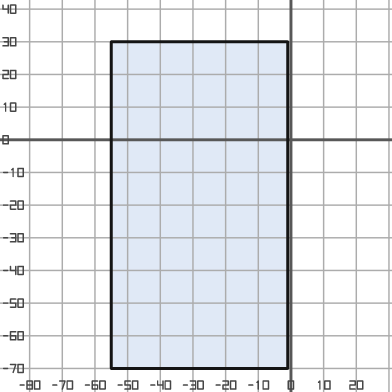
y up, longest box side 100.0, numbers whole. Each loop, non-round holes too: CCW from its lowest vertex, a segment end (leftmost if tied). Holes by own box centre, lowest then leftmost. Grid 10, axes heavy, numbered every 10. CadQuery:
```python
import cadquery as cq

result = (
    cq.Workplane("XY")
    .moveTo(-55.0, -70.0)
    .lineTo(-1.0, -70.0)
    .lineTo(-1.0, 30.0)
    .lineTo(-55.0, 30.0)
    .close()
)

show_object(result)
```